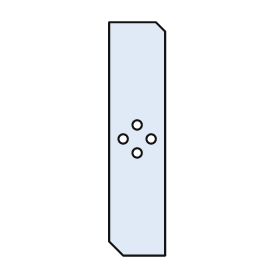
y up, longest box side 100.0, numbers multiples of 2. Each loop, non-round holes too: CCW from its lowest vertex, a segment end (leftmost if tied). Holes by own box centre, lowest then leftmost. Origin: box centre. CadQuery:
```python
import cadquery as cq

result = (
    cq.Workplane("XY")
    .moveTo(-6.0, -50.0)
    .lineTo(12.0, -50.0)
    .lineTo(12.0, 46.0)
    .lineTo(8.0, 50.0)
    .lineTo(-12.0, 50.0)
    .lineTo(-12.0, -44.0)
    .close()
    .moveTo(0.0, -6.0)
    .circle(2.0)
    .moveTo(-6.0, 0.0)
    .circle(2.0)
    .moveTo(6.0, 0.0)
    .circle(2.0)
    .moveTo(0.0, 6.0)
    .circle(2.0)
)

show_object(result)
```